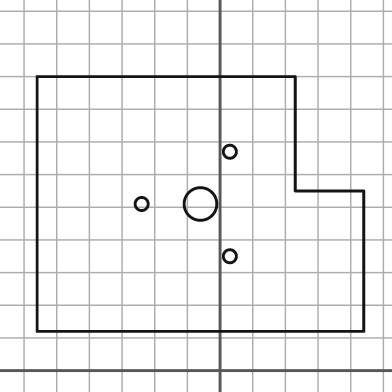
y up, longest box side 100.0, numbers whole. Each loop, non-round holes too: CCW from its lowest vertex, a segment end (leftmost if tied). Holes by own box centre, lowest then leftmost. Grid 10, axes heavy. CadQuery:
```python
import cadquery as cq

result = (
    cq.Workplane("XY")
    .moveTo(-56.0, 12.0)
    .lineTo(44.0, 12.0)
    .lineTo(44.0, 55.0)
    .lineTo(23.0, 55.0)
    .lineTo(23.0, 90.0)
    .lineTo(-56.0, 90.0)
    .close()
    .moveTo(3.0, 35.0)
    .circle(2.0)
    .moveTo(-24.0, 51.0)
    .circle(2.0)
    .moveTo(-6.0, 51.0)
    .circle(5.0)
    .moveTo(3.0, 67.0)
    .circle(2.0)
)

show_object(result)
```